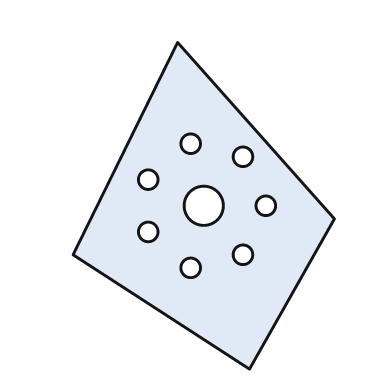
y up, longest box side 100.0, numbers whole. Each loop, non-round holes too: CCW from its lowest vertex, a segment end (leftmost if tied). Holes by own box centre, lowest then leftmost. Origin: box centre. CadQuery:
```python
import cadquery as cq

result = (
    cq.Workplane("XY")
    .moveTo(14.0, -50.0)
    .lineTo(40.0, -4.0)
    .lineTo(-8.0, 50.0)
    .lineTo(-40.0, -15.0)
    .close()
    .moveTo(-4.0, -19.0)
    .circle(3.0)
    .moveTo(12.0, -15.0)
    .circle(3.0)
    .moveTo(-17.0, -8.0)
    .circle(3.0)
    .moveTo(0.0, 0.0)
    .circle(6.0)
    .moveTo(19.0, 0.0)
    .circle(3.0)
    .moveTo(-17.0, 8.0)
    .circle(3.0)
    .moveTo(12.0, 15.0)
    .circle(3.0)
    .moveTo(-4.0, 19.0)
    .circle(3.0)
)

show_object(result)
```